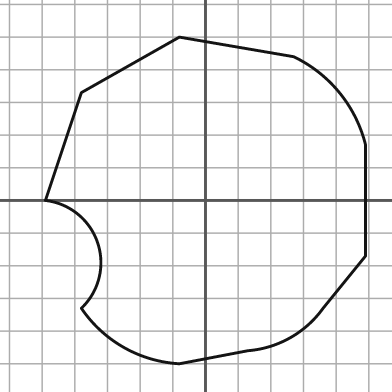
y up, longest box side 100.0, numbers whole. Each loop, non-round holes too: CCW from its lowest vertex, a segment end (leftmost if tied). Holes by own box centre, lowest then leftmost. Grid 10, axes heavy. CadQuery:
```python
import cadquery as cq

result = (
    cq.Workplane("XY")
    .moveTo(-8.0, -50.0)
    .lineTo(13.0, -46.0)
    .threePointArc((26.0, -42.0), (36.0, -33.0))
    .lineTo(49.0, -17.0)
    .lineTo(49.0, 17.0)
    .threePointArc((41.0, 33.0), (27.0, 44.0))
    .lineTo(-8.0, 50.0)
    .lineTo(-38.0, 33.0)
    .lineTo(-49.0, 0.0)
    .threePointArc((-33.0, -13.0), (-38.0, -33.0))
    .threePointArc((-25.0, -45.0), (-8.0, -50.0))
    .close()
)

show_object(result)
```